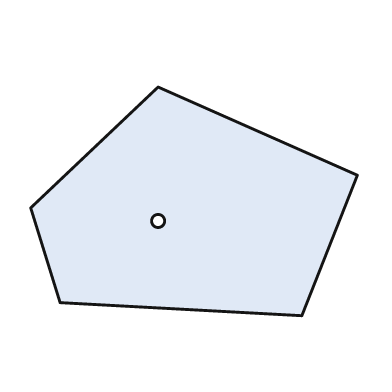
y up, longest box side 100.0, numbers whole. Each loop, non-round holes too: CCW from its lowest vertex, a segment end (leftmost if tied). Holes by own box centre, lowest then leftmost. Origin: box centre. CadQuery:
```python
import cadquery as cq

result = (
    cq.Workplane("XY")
    .moveTo(33.0, -35.0)
    .lineTo(50.0, 8.0)
    .lineTo(-11.0, 35.0)
    .lineTo(-50.0, -2.0)
    .lineTo(-41.0, -31.0)
    .close()
    .moveTo(-11.0, -6.0)
    .circle(2.0)
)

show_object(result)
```